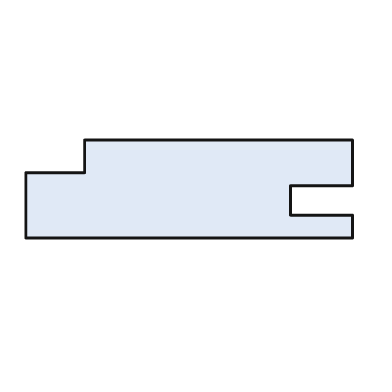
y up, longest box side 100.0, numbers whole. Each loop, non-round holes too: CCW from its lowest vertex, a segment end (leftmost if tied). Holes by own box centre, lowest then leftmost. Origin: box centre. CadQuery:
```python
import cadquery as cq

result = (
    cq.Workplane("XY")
    .moveTo(-50.0, -15.0)
    .lineTo(50.0, -15.0)
    .lineTo(50.0, -8.0)
    .lineTo(31.0, -8.0)
    .lineTo(31.0, 1.0)
    .lineTo(50.0, 1.0)
    .lineTo(50.0, 15.0)
    .lineTo(-32.0, 15.0)
    .lineTo(-32.0, 5.0)
    .lineTo(-50.0, 5.0)
    .close()
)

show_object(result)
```